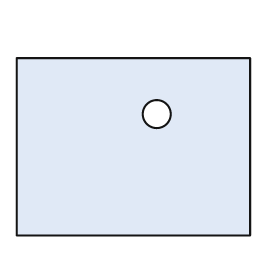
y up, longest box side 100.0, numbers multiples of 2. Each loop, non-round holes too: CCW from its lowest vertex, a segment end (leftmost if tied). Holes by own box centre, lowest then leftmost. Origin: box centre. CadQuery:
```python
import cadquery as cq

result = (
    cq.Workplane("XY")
    .moveTo(-50.0, -38.0)
    .lineTo(50.0, -38.0)
    .lineTo(50.0, 38.0)
    .lineTo(-50.0, 38.0)
    .close()
    .moveTo(10.0, 14.0)
    .circle(6.0)
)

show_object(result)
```